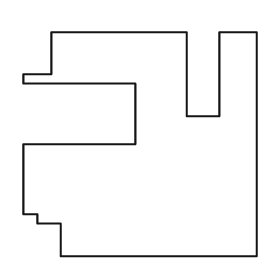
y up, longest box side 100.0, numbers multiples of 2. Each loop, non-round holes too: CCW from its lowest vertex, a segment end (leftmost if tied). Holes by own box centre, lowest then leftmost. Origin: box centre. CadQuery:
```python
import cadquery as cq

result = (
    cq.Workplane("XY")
    .moveTo(-34.0, -48.0)
    .lineTo(50.0, -48.0)
    .lineTo(50.0, 48.0)
    .lineTo(34.0, 48.0)
    .lineTo(34.0, 12.0)
    .lineTo(20.0, 12.0)
    .lineTo(20.0, 48.0)
    .lineTo(-38.0, 48.0)
    .lineTo(-38.0, 30.0)
    .lineTo(-50.0, 30.0)
    .lineTo(-50.0, 26.0)
    .lineTo(-2.0, 26.0)
    .lineTo(-2.0, 0.0)
    .lineTo(-50.0, 0.0)
    .lineTo(-50.0, -30.0)
    .lineTo(-44.0, -30.0)
    .lineTo(-44.0, -34.0)
    .lineTo(-34.0, -34.0)
    .close()
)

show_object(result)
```